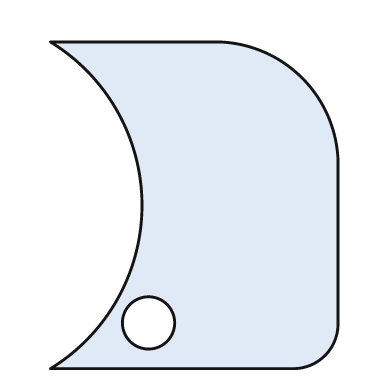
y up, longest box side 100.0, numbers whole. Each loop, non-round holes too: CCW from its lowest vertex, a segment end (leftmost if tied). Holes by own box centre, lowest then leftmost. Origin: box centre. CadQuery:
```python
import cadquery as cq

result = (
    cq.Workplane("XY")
    .moveTo(-44.0, -50.0)
    .lineTo(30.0, -50.0)
    .threePointArc((40.0, -46.0), (44.0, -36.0))
    .lineTo(44.0, 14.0)
    .threePointArc((33.0, 39.0), (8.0, 50.0))
    .lineTo(-44.0, 50.0)
    .threePointArc((-16.0, 0.0), (-44.0, -50.0))
    .close()
    .moveTo(-14.0, -36.0)
    .circle(8.0)
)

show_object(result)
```